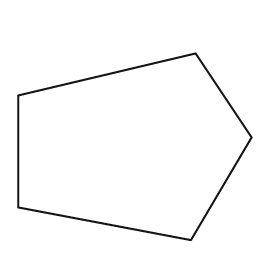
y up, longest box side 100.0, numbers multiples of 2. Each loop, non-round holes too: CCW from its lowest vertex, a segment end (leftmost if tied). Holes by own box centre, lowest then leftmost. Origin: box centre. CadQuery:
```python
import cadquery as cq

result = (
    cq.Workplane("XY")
    .moveTo(24.0, -40.0)
    .lineTo(50.0, 4.0)
    .lineTo(26.0, 40.0)
    .lineTo(-50.0, 22.0)
    .lineTo(-50.0, -26.0)
    .close()
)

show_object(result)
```